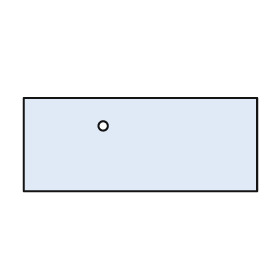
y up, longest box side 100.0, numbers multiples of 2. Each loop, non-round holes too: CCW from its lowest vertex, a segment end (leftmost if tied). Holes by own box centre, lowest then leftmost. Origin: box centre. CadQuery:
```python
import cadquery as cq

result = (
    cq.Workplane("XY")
    .moveTo(-50.0, -20.0)
    .lineTo(50.0, -20.0)
    .lineTo(50.0, 20.0)
    .lineTo(-50.0, 20.0)
    .close()
    .moveTo(-16.0, 8.0)
    .circle(2.0)
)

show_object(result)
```